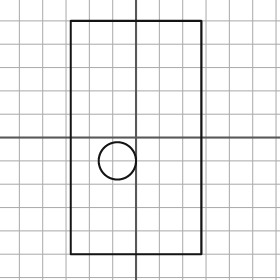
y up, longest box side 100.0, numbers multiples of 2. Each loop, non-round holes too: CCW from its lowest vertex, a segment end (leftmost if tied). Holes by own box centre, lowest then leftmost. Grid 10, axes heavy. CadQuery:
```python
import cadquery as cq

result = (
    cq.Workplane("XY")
    .moveTo(-28.0, -50.0)
    .lineTo(28.0, -50.0)
    .lineTo(28.0, 50.0)
    .lineTo(-28.0, 50.0)
    .close()
    .moveTo(-8.0, -10.0)
    .circle(8.0)
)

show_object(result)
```